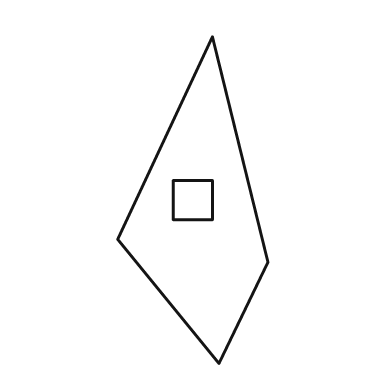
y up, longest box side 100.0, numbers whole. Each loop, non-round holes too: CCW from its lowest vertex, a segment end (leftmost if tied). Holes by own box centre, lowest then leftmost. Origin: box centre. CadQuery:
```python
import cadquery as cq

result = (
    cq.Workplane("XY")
    .moveTo(8.0, -50.0)
    .lineTo(23.0, -19.0)
    .lineTo(6.0, 50.0)
    .lineTo(-23.0, -12.0)
    .close()
    .moveTo(-6.0, -6.0)
    .lineTo(6.0, -6.0)
    .lineTo(6.0, 6.0)
    .lineTo(-6.0, 6.0)
    .close()
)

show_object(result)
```